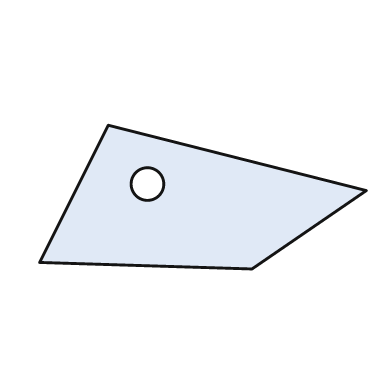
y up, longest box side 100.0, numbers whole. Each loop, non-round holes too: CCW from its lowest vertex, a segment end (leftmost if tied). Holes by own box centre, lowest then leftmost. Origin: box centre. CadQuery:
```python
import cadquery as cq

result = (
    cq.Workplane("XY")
    .moveTo(15.0, -22.0)
    .lineTo(50.0, 2.0)
    .lineTo(-29.0, 22.0)
    .lineTo(-50.0, -20.0)
    .close()
    .moveTo(-17.0, 4.0)
    .circle(5.0)
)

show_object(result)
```